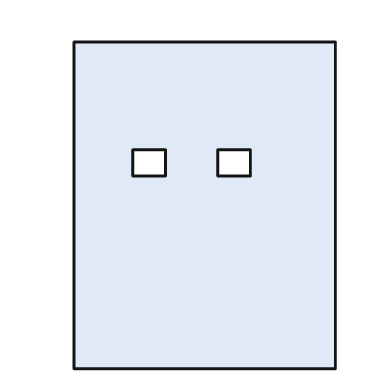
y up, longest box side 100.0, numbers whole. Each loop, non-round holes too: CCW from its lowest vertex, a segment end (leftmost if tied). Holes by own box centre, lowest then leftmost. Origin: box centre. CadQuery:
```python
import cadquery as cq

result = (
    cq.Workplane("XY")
    .moveTo(-40.0, -50.0)
    .lineTo(40.0, -50.0)
    .lineTo(40.0, 50.0)
    .lineTo(-40.0, 50.0)
    .close()
    .moveTo(-22.0, 9.0)
    .lineTo(-12.0, 9.0)
    .lineTo(-12.0, 17.0)
    .lineTo(-22.0, 17.0)
    .close()
    .moveTo(4.0, 9.0)
    .lineTo(14.0, 9.0)
    .lineTo(14.0, 17.0)
    .lineTo(4.0, 17.0)
    .close()
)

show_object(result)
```